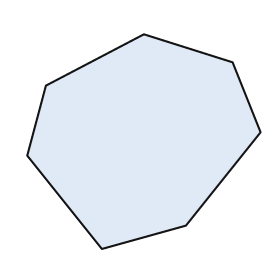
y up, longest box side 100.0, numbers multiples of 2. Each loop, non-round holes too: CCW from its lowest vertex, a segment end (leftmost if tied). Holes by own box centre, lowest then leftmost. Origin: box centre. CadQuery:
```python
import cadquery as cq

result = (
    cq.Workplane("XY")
    .moveTo(-18.0, -46.0)
    .lineTo(18.0, -36.0)
    .lineTo(50.0, 4.0)
    .lineTo(38.0, 34.0)
    .lineTo(0.0, 46.0)
    .lineTo(-42.0, 24.0)
    .lineTo(-50.0, -6.0)
    .close()
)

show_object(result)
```